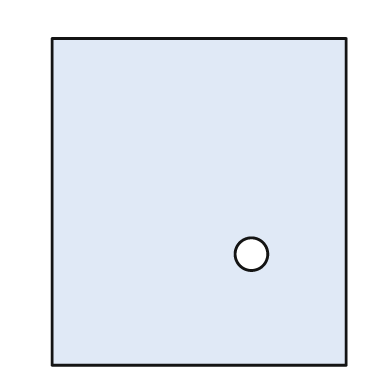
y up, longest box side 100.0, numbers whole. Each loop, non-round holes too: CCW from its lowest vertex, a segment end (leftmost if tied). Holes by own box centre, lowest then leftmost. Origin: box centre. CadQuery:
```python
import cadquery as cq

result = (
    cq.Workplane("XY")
    .moveTo(-45.0, -50.0)
    .lineTo(45.0, -50.0)
    .lineTo(45.0, 50.0)
    .lineTo(-45.0, 50.0)
    .close()
    .moveTo(16.0, -16.0)
    .circle(5.0)
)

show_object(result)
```